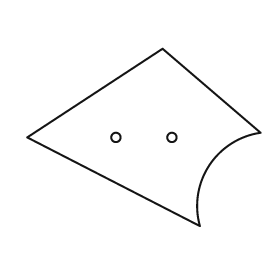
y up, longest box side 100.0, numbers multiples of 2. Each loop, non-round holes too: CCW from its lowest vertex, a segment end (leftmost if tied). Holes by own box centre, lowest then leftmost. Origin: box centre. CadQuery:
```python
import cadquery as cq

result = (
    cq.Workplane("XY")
    .moveTo(24.0, -38.0)
    .threePointArc((28.0, -12.0), (50.0, 2.0))
    .lineTo(8.0, 38.0)
    .lineTo(-50.0, 0.0)
    .close()
    .moveTo(-12.0, 0.0)
    .circle(2.0)
    .moveTo(12.0, 0.0)
    .circle(2.0)
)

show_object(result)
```